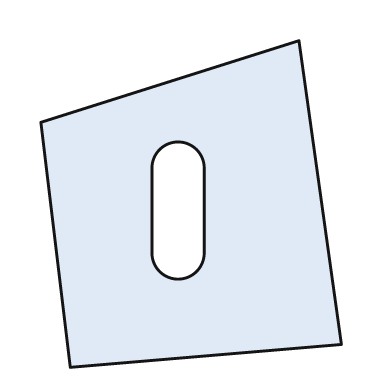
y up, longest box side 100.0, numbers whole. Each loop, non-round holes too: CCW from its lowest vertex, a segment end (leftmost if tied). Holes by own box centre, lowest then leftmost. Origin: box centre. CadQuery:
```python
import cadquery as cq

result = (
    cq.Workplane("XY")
    .moveTo(-37.0, -50.0)
    .lineTo(46.0, -43.0)
    .lineTo(33.0, 50.0)
    .lineTo(-46.0, 25.0)
    .close()
    .moveTo(-12.0, -15.0)
    .threePointArc((-4.0, -23.0), (4.0, -15.0))
    .lineTo(4.0, 11.0)
    .threePointArc((-4.0, 19.0), (-12.0, 11.0))
    .close()
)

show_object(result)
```